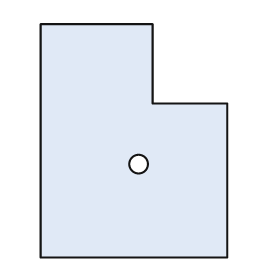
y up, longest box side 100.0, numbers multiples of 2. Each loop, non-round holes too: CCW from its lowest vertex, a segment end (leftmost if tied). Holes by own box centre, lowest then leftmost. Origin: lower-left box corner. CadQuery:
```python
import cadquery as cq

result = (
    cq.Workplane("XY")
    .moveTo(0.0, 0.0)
    .lineTo(80.0, 0.0)
    .lineTo(80.0, 66.0)
    .lineTo(48.0, 66.0)
    .lineTo(48.0, 100.0)
    .lineTo(0.0, 100.0)
    .close()
    .moveTo(42.0, 40.0)
    .circle(4.0)
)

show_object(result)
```